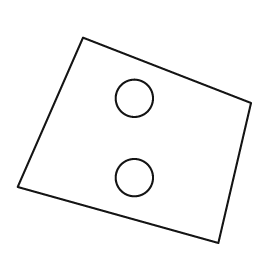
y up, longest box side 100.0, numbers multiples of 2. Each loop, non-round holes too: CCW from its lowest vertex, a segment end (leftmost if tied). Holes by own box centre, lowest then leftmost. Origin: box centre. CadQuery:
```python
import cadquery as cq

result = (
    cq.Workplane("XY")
    .moveTo(36.0, -44.0)
    .lineTo(50.0, 16.0)
    .lineTo(-22.0, 44.0)
    .lineTo(-50.0, -20.0)
    .close()
    .moveTo(0.0, -16.0)
    .circle(8.0)
    .moveTo(0.0, 18.0)
    .circle(8.0)
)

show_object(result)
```